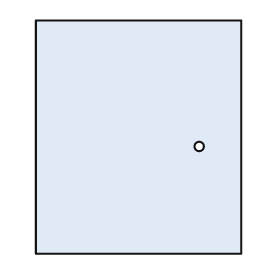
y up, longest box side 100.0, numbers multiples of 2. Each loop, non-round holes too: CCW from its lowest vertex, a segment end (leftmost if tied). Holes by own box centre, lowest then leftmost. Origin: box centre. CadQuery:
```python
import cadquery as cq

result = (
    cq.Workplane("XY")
    .moveTo(-44.0, -50.0)
    .lineTo(44.0, -50.0)
    .lineTo(44.0, 50.0)
    .lineTo(-44.0, 50.0)
    .close()
    .moveTo(26.0, -4.0)
    .circle(2.0)
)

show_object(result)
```